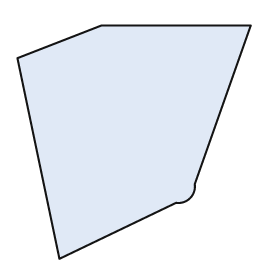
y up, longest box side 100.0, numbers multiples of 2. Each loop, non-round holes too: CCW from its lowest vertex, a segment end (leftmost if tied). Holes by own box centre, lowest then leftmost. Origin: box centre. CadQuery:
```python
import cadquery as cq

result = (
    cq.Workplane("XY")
    .moveTo(-32.0, -50.0)
    .lineTo(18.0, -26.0)
    .threePointArc((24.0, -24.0), (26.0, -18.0))
    .lineTo(50.0, 50.0)
    .lineTo(-14.0, 50.0)
    .lineTo(-50.0, 36.0)
    .close()
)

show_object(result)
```